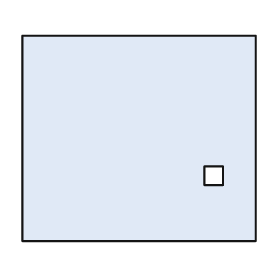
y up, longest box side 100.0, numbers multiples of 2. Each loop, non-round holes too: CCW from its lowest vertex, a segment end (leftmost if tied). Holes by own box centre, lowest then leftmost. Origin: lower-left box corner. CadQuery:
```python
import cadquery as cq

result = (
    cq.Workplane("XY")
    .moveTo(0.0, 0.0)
    .lineTo(100.0, 0.0)
    .lineTo(100.0, 88.0)
    .lineTo(0.0, 88.0)
    .close()
    .moveTo(78.0, 24.0)
    .lineTo(86.0, 24.0)
    .lineTo(86.0, 32.0)
    .lineTo(78.0, 32.0)
    .close()
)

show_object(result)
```